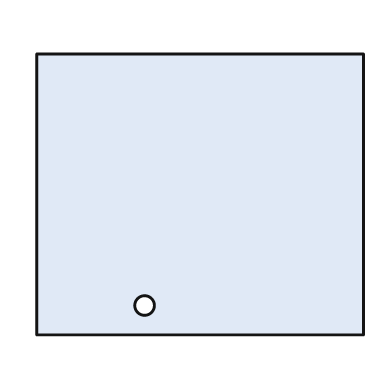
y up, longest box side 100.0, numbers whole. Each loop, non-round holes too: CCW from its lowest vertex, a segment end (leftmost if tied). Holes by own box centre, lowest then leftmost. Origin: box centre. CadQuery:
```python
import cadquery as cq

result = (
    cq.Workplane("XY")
    .moveTo(-50.0, -43.0)
    .lineTo(50.0, -43.0)
    .lineTo(50.0, 43.0)
    .lineTo(-50.0, 43.0)
    .close()
    .moveTo(-17.0, -34.0)
    .circle(3.0)
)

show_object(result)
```